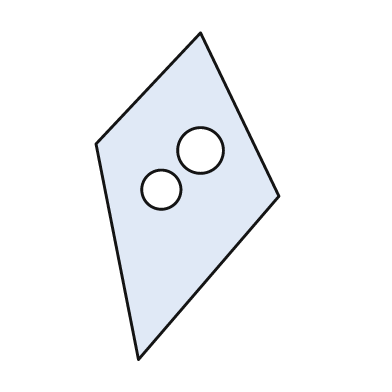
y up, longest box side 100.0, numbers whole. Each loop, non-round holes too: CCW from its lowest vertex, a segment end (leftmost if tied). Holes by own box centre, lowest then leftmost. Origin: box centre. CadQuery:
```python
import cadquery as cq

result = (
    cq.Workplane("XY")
    .moveTo(-15.0, -50.0)
    .lineTo(28.0, 0.0)
    .lineTo(4.0, 50.0)
    .lineTo(-28.0, 16.0)
    .close()
    .moveTo(-8.0, 2.0)
    .circle(6.0)
    .moveTo(4.0, 14.0)
    .circle(7.0)
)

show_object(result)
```